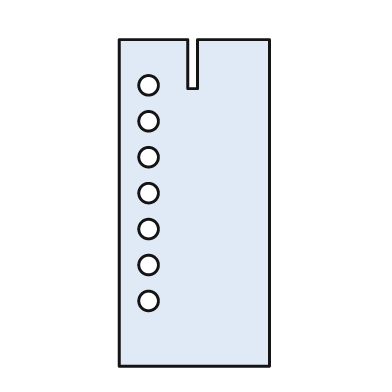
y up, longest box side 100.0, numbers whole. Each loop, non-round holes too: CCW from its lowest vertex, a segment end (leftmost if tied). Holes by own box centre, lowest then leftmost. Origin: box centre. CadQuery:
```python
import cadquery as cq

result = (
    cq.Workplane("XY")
    .moveTo(-23.0, -50.0)
    .lineTo(23.0, -50.0)
    .lineTo(23.0, 50.0)
    .lineTo(1.0, 50.0)
    .lineTo(1.0, 35.0)
    .lineTo(-2.0, 35.0)
    .lineTo(-2.0, 50.0)
    .lineTo(-23.0, 50.0)
    .close()
    .moveTo(-14.0, -30.0)
    .circle(3.0)
    .moveTo(-14.0, -19.0)
    .circle(3.0)
    .moveTo(-14.0, -8.0)
    .circle(3.0)
    .moveTo(-14.0, 3.0)
    .circle(3.0)
    .moveTo(-14.0, 14.0)
    .circle(3.0)
    .moveTo(-14.0, 25.0)
    .circle(3.0)
    .moveTo(-14.0, 36.0)
    .circle(3.0)
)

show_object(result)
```